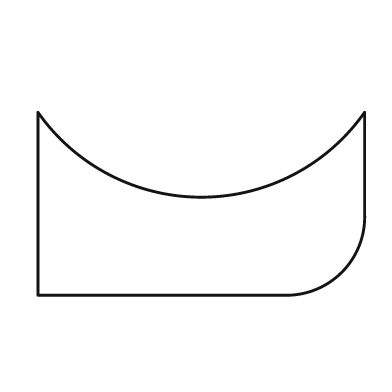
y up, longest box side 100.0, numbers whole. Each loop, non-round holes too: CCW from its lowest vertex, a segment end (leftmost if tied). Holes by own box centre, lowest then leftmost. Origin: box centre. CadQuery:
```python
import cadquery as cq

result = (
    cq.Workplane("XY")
    .moveTo(-50.0, -28.0)
    .lineTo(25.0, -28.0)
    .threePointArc((43.0, -21.0), (50.0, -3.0))
    .lineTo(50.0, 28.0)
    .threePointArc((0.0, 2.0), (-50.0, 28.0))
    .close()
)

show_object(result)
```